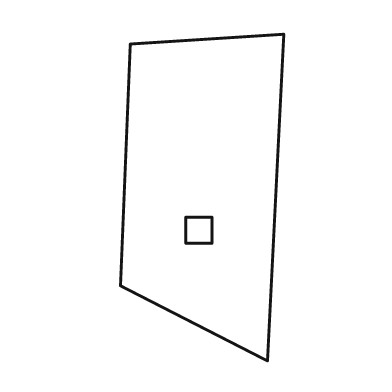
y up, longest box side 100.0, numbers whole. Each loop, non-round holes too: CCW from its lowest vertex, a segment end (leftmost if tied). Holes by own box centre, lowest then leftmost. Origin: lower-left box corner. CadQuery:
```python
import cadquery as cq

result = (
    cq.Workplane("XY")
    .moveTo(45.0, 0.0)
    .lineTo(50.0, 100.0)
    .lineTo(3.0, 97.0)
    .lineTo(0.0, 23.0)
    .close()
    .moveTo(20.0, 36.0)
    .lineTo(28.0, 36.0)
    .lineTo(28.0, 44.0)
    .lineTo(20.0, 44.0)
    .close()
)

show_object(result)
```